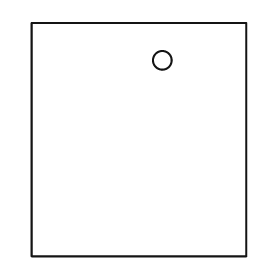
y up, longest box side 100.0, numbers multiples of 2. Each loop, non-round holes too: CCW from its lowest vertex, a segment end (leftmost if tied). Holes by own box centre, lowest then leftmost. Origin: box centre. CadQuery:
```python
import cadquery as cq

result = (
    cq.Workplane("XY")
    .moveTo(-46.0, -50.0)
    .lineTo(46.0, -50.0)
    .lineTo(46.0, 50.0)
    .lineTo(-46.0, 50.0)
    .close()
    .moveTo(10.0, 34.0)
    .circle(4.0)
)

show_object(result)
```